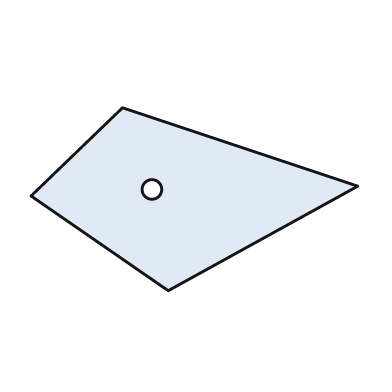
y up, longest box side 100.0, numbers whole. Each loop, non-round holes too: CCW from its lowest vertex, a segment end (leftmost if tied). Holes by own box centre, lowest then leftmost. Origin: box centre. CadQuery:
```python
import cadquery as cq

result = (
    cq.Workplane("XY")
    .moveTo(-8.0, -28.0)
    .lineTo(50.0, 4.0)
    .lineTo(-22.0, 28.0)
    .lineTo(-50.0, 1.0)
    .close()
    .moveTo(-13.0, 3.0)
    .circle(3.0)
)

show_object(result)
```